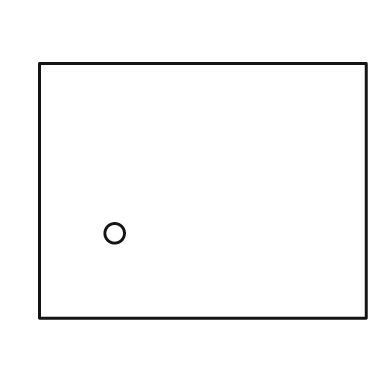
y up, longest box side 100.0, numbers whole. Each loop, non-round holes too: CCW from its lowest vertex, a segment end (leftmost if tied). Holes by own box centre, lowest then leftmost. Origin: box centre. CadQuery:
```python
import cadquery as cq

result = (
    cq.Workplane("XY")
    .moveTo(-50.0, -39.0)
    .lineTo(50.0, -39.0)
    .lineTo(50.0, 39.0)
    .lineTo(-50.0, 39.0)
    .close()
    .moveTo(-27.0, -13.0)
    .circle(3.0)
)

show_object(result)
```